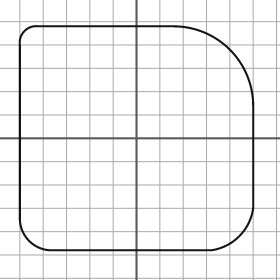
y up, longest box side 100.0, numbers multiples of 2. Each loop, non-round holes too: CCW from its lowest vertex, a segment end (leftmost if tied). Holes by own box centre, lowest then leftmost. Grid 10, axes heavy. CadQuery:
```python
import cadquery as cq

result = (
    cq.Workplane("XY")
    .moveTo(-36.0, -48.0)
    .lineTo(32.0, -48.0)
    .threePointArc((44.0, -42.0), (50.0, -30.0))
    .lineTo(50.0, 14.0)
    .threePointArc((40.0, 38.0), (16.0, 48.0))
    .lineTo(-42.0, 48.0)
    .threePointArc((-48.0, 46.0), (-50.0, 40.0))
    .lineTo(-50.0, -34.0)
    .threePointArc((-46.0, -44.0), (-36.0, -48.0))
    .close()
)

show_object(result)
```